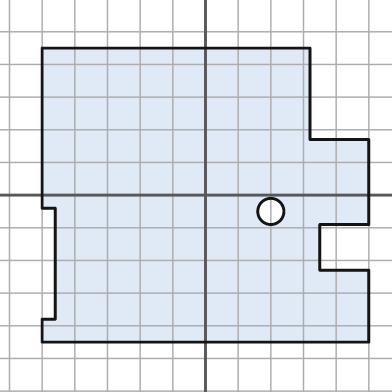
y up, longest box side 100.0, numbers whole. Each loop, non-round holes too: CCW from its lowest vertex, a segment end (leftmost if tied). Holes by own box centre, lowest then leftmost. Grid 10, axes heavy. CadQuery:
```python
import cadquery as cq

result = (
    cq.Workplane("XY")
    .moveTo(-50.0, -45.0)
    .lineTo(50.0, -45.0)
    .lineTo(50.0, -23.0)
    .lineTo(35.0, -23.0)
    .lineTo(35.0, -9.0)
    .lineTo(50.0, -9.0)
    .lineTo(50.0, 17.0)
    .lineTo(32.0, 17.0)
    .lineTo(32.0, 45.0)
    .lineTo(-50.0, 45.0)
    .lineTo(-50.0, -4.0)
    .lineTo(-46.0, -4.0)
    .lineTo(-46.0, -38.0)
    .lineTo(-50.0, -38.0)
    .close()
    .moveTo(20.0, -5.0)
    .circle(4.0)
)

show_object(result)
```